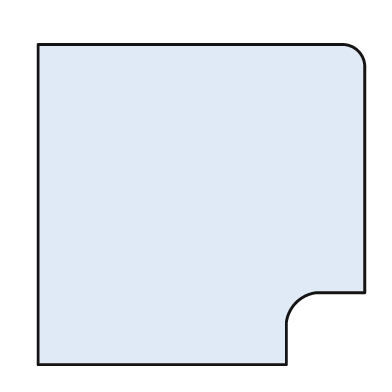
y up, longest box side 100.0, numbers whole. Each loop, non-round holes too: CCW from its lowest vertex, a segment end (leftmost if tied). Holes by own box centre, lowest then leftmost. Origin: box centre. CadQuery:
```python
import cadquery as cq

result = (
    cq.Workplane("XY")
    .moveTo(-50.0, -49.0)
    .lineTo(26.0, -49.0)
    .lineTo(26.0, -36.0)
    .threePointArc((29.0, -30.0), (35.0, -27.0))
    .lineTo(50.0, -27.0)
    .lineTo(50.0, 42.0)
    .threePointArc((48.0, 47.0), (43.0, 49.0))
    .lineTo(-50.0, 49.0)
    .close()
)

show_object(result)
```